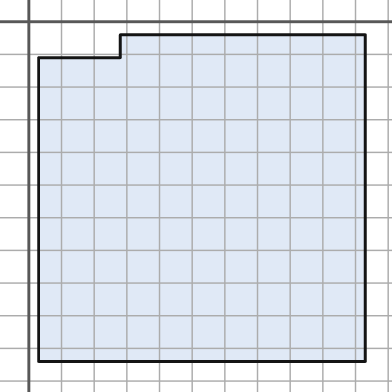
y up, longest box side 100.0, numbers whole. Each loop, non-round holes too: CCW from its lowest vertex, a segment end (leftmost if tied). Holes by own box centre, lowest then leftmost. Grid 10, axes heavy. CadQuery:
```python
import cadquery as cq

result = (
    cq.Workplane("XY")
    .moveTo(3.0, -104.0)
    .lineTo(103.0, -104.0)
    .lineTo(103.0, -4.0)
    .lineTo(28.0, -4.0)
    .lineTo(28.0, -11.0)
    .lineTo(3.0, -11.0)
    .close()
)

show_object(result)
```